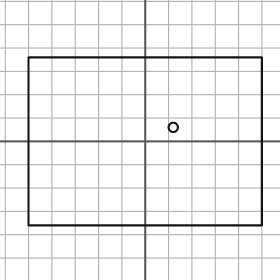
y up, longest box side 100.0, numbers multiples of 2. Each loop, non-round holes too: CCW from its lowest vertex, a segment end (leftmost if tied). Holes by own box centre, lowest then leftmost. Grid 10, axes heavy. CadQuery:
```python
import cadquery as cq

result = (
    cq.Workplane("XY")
    .moveTo(-50.0, -36.0)
    .lineTo(50.0, -36.0)
    .lineTo(50.0, 36.0)
    .lineTo(-50.0, 36.0)
    .close()
    .moveTo(12.0, 6.0)
    .circle(2.0)
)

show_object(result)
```